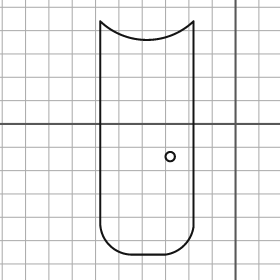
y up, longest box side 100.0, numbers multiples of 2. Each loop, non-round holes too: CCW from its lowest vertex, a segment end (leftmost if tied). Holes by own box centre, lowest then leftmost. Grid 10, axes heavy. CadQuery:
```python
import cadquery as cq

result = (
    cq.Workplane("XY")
    .moveTo(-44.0, -56.0)
    .lineTo(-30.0, -56.0)
    .threePointArc((-22.0, -52.0), (-18.0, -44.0))
    .lineTo(-18.0, 44.0)
    .threePointArc((-38.0, 36.0), (-58.0, 44.0))
    .lineTo(-58.0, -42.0)
    .threePointArc((-54.0, -52.0), (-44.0, -56.0))
    .close()
    .moveTo(-28.0, -14.0)
    .circle(2.0)
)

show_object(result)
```